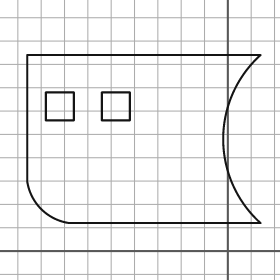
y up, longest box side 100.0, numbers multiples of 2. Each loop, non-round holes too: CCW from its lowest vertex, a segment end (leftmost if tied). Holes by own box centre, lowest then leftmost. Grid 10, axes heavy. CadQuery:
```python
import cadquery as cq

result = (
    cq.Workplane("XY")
    .moveTo(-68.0, 12.0)
    .lineTo(14.0, 12.0)
    .threePointArc((-2.0, 48.0), (14.0, 84.0))
    .lineTo(-86.0, 84.0)
    .lineTo(-86.0, 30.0)
    .threePointArc((-80.0, 18.0), (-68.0, 12.0))
    .close()
    .moveTo(-78.0, 56.0)
    .lineTo(-66.0, 56.0)
    .lineTo(-66.0, 68.0)
    .lineTo(-78.0, 68.0)
    .close()
    .moveTo(-54.0, 56.0)
    .lineTo(-42.0, 56.0)
    .lineTo(-42.0, 68.0)
    .lineTo(-54.0, 68.0)
    .close()
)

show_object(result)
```